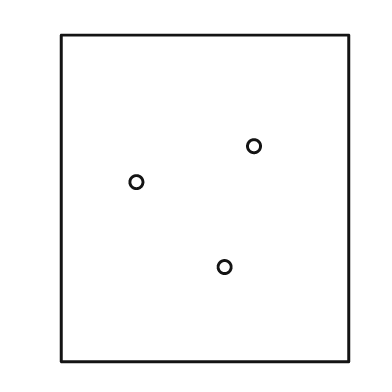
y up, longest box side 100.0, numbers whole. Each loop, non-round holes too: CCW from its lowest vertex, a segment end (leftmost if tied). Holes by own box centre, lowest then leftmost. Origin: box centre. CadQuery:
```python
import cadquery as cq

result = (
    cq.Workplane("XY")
    .moveTo(-44.0, -50.0)
    .lineTo(44.0, -50.0)
    .lineTo(44.0, 50.0)
    .lineTo(-44.0, 50.0)
    .close()
    .moveTo(6.0, -21.0)
    .circle(2.0)
    .moveTo(-21.0, 5.0)
    .circle(2.0)
    .moveTo(15.0, 16.0)
    .circle(2.0)
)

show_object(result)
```